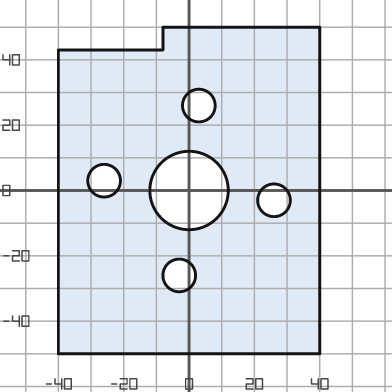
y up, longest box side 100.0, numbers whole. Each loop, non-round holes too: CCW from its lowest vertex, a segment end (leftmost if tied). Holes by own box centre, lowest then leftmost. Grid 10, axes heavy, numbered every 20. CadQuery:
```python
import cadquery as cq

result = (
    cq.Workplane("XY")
    .moveTo(-40.0, -50.0)
    .lineTo(40.0, -50.0)
    .lineTo(40.0, 50.0)
    .lineTo(-8.0, 50.0)
    .lineTo(-8.0, 43.0)
    .lineTo(-40.0, 43.0)
    .close()
    .moveTo(-3.0, -26.0)
    .circle(5.0)
    .moveTo(26.0, -3.0)
    .circle(5.0)
    .moveTo(0.0, 0.0)
    .circle(12.0)
    .moveTo(-26.0, 3.0)
    .circle(5.0)
    .moveTo(3.0, 26.0)
    .circle(5.0)
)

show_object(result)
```